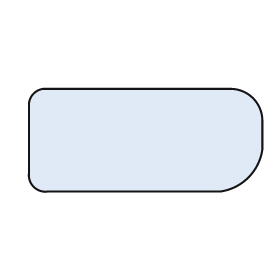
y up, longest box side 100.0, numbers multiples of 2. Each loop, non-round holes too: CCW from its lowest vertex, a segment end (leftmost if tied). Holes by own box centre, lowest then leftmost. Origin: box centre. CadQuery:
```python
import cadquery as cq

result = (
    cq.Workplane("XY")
    .moveTo(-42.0, -22.0)
    .lineTo(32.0, -22.0)
    .threePointArc((44.0, -16.0), (50.0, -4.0))
    .lineTo(50.0, 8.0)
    .threePointArc((46.0, 18.0), (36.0, 22.0))
    .lineTo(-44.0, 22.0)
    .threePointArc((-48.0, 20.0), (-50.0, 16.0))
    .lineTo(-50.0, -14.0)
    .threePointArc((-48.0, -20.0), (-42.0, -22.0))
    .close()
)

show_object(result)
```